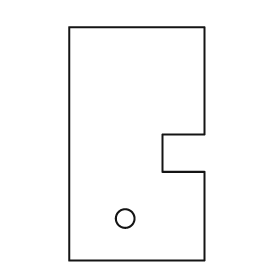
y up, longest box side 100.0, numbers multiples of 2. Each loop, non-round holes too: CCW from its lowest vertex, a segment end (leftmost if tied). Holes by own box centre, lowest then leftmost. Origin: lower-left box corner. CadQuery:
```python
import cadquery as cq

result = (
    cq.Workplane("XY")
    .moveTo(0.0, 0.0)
    .lineTo(58.0, 0.0)
    .lineTo(58.0, 38.0)
    .lineTo(40.0, 38.0)
    .lineTo(40.0, 54.0)
    .lineTo(58.0, 54.0)
    .lineTo(58.0, 100.0)
    .lineTo(0.0, 100.0)
    .close()
    .moveTo(24.0, 18.0)
    .circle(4.0)
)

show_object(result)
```